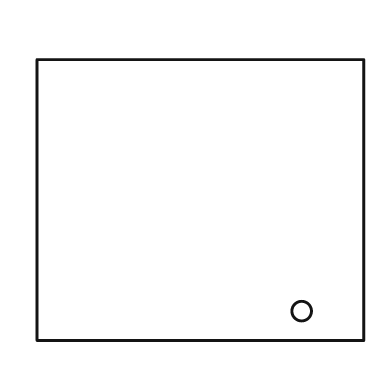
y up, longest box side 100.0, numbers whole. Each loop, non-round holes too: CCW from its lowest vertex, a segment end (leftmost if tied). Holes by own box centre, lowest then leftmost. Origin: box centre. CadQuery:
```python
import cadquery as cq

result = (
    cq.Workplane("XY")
    .moveTo(-50.0, -43.0)
    .lineTo(50.0, -43.0)
    .lineTo(50.0, 43.0)
    .lineTo(-50.0, 43.0)
    .close()
    .moveTo(31.0, -34.0)
    .circle(3.0)
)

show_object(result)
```